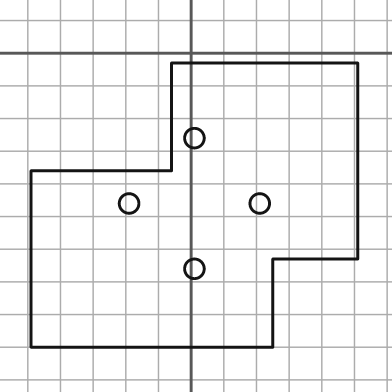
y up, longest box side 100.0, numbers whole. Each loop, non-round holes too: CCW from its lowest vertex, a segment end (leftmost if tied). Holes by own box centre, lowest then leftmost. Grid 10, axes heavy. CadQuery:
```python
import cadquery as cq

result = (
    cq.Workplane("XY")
    .moveTo(-49.0, -90.0)
    .lineTo(25.0, -90.0)
    .lineTo(25.0, -63.0)
    .lineTo(51.0, -63.0)
    .lineTo(51.0, -3.0)
    .lineTo(-6.0, -3.0)
    .lineTo(-6.0, -36.0)
    .lineTo(-49.0, -36.0)
    .close()
    .moveTo(1.0, -66.0)
    .circle(3.0)
    .moveTo(-19.0, -46.0)
    .circle(3.0)
    .moveTo(21.0, -46.0)
    .circle(3.0)
    .moveTo(1.0, -26.0)
    .circle(3.0)
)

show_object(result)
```